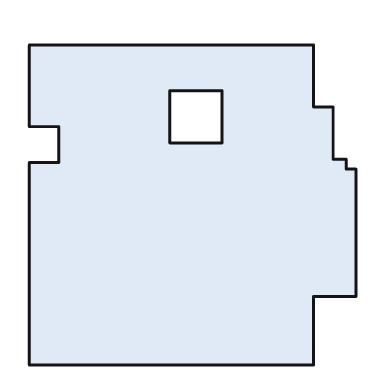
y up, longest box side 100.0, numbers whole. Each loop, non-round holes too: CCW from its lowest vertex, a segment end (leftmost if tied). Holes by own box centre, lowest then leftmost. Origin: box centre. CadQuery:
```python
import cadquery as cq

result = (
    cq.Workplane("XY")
    .moveTo(-50.0, -49.0)
    .lineTo(37.0, -49.0)
    .lineTo(37.0, -28.0)
    .lineTo(50.0, -28.0)
    .lineTo(50.0, 11.0)
    .lineTo(47.0, 11.0)
    .lineTo(47.0, 14.0)
    .lineTo(43.0, 14.0)
    .lineTo(43.0, 30.0)
    .lineTo(37.0, 30.0)
    .lineTo(37.0, 49.0)
    .lineTo(-50.0, 49.0)
    .lineTo(-50.0, 24.0)
    .lineTo(-41.0, 24.0)
    .lineTo(-41.0, 13.0)
    .lineTo(-50.0, 13.0)
    .close()
    .moveTo(-7.0, 19.0)
    .lineTo(9.0, 19.0)
    .lineTo(9.0, 35.0)
    .lineTo(-7.0, 35.0)
    .close()
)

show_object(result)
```